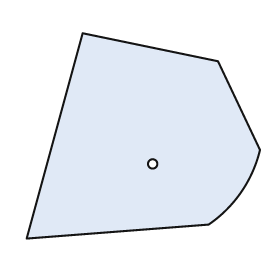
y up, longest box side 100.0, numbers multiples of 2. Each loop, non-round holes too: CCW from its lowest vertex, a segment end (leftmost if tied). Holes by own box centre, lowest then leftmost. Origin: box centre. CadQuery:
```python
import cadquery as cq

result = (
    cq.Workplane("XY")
    .moveTo(-50.0, -44.0)
    .lineTo(28.0, -38.0)
    .threePointArc((42.0, -24.0), (50.0, -6.0))
    .lineTo(32.0, 32.0)
    .lineTo(-26.0, 44.0)
    .close()
    .moveTo(4.0, -12.0)
    .circle(2.0)
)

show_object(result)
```